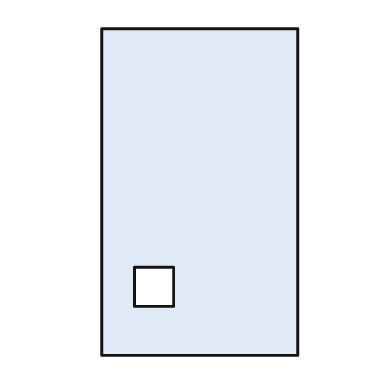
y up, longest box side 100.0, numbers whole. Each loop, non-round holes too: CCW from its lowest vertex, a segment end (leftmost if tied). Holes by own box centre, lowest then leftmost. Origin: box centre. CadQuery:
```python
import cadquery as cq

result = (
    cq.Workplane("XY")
    .moveTo(-30.0, -50.0)
    .lineTo(30.0, -50.0)
    .lineTo(30.0, 50.0)
    .lineTo(-30.0, 50.0)
    .close()
    .moveTo(-20.0, -35.0)
    .lineTo(-8.0, -35.0)
    .lineTo(-8.0, -23.0)
    .lineTo(-20.0, -23.0)
    .close()
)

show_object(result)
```